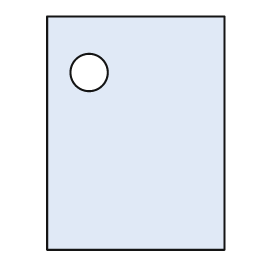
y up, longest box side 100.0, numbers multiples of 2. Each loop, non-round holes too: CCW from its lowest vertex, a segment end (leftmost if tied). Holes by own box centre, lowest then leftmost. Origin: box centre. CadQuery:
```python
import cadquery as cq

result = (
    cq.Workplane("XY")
    .moveTo(-38.0, -50.0)
    .lineTo(38.0, -50.0)
    .lineTo(38.0, 50.0)
    .lineTo(-38.0, 50.0)
    .close()
    .moveTo(-20.0, 26.0)
    .circle(8.0)
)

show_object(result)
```